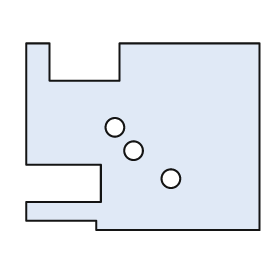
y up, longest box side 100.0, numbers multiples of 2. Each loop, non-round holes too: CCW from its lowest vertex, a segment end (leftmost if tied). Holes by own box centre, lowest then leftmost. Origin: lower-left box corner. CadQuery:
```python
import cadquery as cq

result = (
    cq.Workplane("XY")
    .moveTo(30.0, 0.0)
    .lineTo(100.0, 0.0)
    .lineTo(100.0, 80.0)
    .lineTo(40.0, 80.0)
    .lineTo(40.0, 64.0)
    .lineTo(10.0, 64.0)
    .lineTo(10.0, 80.0)
    .lineTo(0.0, 80.0)
    .lineTo(0.0, 28.0)
    .lineTo(32.0, 28.0)
    .lineTo(32.0, 12.0)
    .lineTo(0.0, 12.0)
    .lineTo(0.0, 4.0)
    .lineTo(30.0, 4.0)
    .close()
    .moveTo(62.0, 22.0)
    .circle(4.0)
    .moveTo(46.0, 34.0)
    .circle(4.0)
    .moveTo(38.0, 44.0)
    .circle(4.0)
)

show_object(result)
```